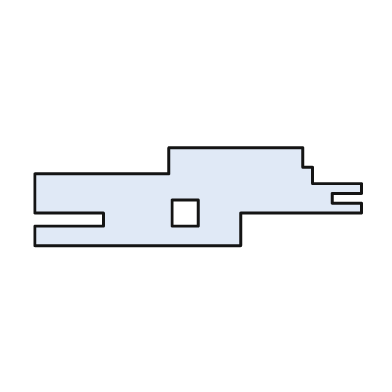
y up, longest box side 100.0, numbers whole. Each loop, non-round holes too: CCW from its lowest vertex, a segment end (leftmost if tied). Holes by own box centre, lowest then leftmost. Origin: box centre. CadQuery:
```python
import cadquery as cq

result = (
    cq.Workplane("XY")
    .moveTo(-50.0, -15.0)
    .lineTo(13.0, -15.0)
    .lineTo(13.0, -5.0)
    .lineTo(50.0, -5.0)
    .lineTo(50.0, -2.0)
    .lineTo(41.0, -2.0)
    .lineTo(41.0, 1.0)
    .lineTo(50.0, 1.0)
    .lineTo(50.0, 4.0)
    .lineTo(35.0, 4.0)
    .lineTo(35.0, 9.0)
    .lineTo(32.0, 9.0)
    .lineTo(32.0, 15.0)
    .lineTo(-9.0, 15.0)
    .lineTo(-9.0, 7.0)
    .lineTo(-50.0, 7.0)
    .lineTo(-50.0, -5.0)
    .lineTo(-29.0, -5.0)
    .lineTo(-29.0, -9.0)
    .lineTo(-50.0, -9.0)
    .close()
    .moveTo(-8.0, -9.0)
    .lineTo(0.0, -9.0)
    .lineTo(0.0, -1.0)
    .lineTo(-8.0, -1.0)
    .close()
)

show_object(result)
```